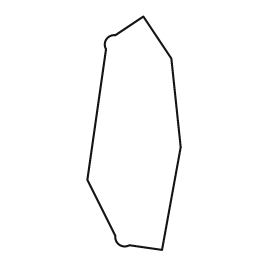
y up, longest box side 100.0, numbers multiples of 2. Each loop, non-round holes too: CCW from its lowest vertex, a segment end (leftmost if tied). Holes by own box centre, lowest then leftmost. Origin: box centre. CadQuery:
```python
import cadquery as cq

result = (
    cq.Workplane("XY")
    .moveTo(12.0, -50.0)
    .lineTo(20.0, -6.0)
    .lineTo(16.0, 32.0)
    .lineTo(4.0, 50.0)
    .lineTo(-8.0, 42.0)
    .threePointArc((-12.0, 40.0), (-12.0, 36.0))
    .lineTo(-20.0, -20.0)
    .lineTo(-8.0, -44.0)
    .threePointArc((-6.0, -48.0), (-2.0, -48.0))
    .close()
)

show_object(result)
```